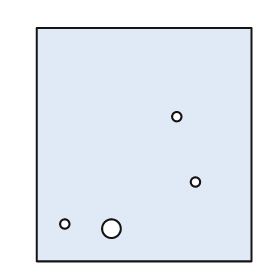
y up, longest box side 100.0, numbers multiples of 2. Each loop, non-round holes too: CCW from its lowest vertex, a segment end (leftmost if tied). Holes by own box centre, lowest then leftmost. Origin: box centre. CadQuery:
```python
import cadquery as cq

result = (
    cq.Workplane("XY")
    .moveTo(-46.0, -50.0)
    .lineTo(46.0, -50.0)
    .lineTo(46.0, 50.0)
    .lineTo(-46.0, 50.0)
    .close()
    .moveTo(-14.0, -36.0)
    .circle(4.0)
    .moveTo(-34.0, -34.0)
    .circle(2.0)
    .moveTo(22.0, -16.0)
    .circle(2.0)
    .moveTo(14.0, 12.0)
    .circle(2.0)
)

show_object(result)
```